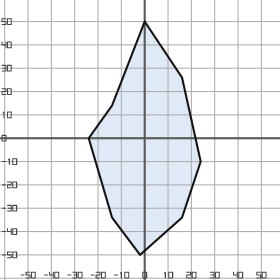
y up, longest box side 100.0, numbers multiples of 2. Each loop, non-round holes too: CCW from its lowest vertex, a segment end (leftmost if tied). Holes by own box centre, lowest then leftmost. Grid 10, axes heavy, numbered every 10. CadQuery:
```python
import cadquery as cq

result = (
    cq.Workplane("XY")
    .moveTo(-2.0, -50.0)
    .lineTo(16.0, -34.0)
    .lineTo(24.0, -10.0)
    .lineTo(16.0, 26.0)
    .lineTo(0.0, 50.0)
    .lineTo(-14.0, 14.0)
    .lineTo(-24.0, 0.0)
    .lineTo(-14.0, -34.0)
    .close()
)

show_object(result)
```